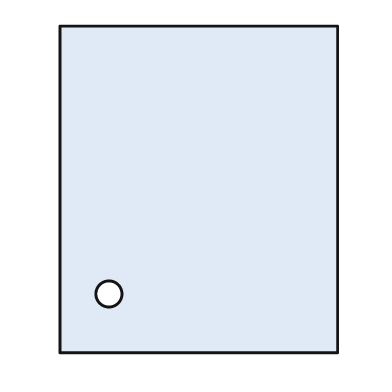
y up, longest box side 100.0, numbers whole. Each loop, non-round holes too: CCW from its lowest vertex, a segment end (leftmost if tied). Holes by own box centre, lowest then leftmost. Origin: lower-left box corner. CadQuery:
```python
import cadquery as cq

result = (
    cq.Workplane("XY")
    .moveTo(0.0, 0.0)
    .lineTo(85.0, 0.0)
    .lineTo(85.0, 100.0)
    .lineTo(0.0, 100.0)
    .close()
    .moveTo(15.0, 18.0)
    .circle(4.0)
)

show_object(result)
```